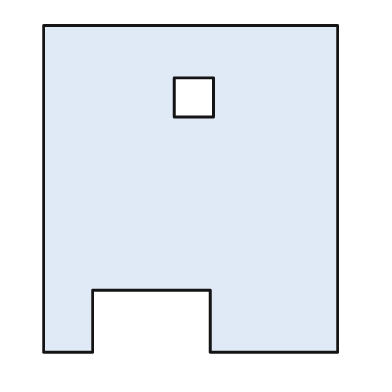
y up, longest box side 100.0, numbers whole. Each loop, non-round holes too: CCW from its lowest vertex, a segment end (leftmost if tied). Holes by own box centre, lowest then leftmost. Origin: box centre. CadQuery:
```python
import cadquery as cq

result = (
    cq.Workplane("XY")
    .moveTo(-45.0, -50.0)
    .lineTo(-30.0, -50.0)
    .lineTo(-30.0, -31.0)
    .lineTo(6.0, -31.0)
    .lineTo(6.0, -50.0)
    .lineTo(45.0, -50.0)
    .lineTo(45.0, 50.0)
    .lineTo(-45.0, 50.0)
    .close()
    .moveTo(-5.0, 22.0)
    .lineTo(7.0, 22.0)
    .lineTo(7.0, 34.0)
    .lineTo(-5.0, 34.0)
    .close()
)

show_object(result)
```